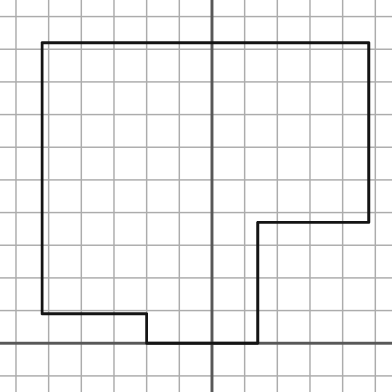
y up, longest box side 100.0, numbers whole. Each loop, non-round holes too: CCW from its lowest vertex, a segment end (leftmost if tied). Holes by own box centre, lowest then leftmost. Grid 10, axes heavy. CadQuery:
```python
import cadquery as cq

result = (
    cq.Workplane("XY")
    .moveTo(-20.0, 0.0)
    .lineTo(14.0, 0.0)
    .lineTo(14.0, 37.0)
    .lineTo(48.0, 37.0)
    .lineTo(48.0, 92.0)
    .lineTo(-52.0, 92.0)
    .lineTo(-52.0, 9.0)
    .lineTo(-20.0, 9.0)
    .close()
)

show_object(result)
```